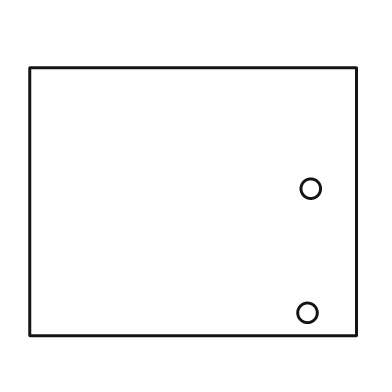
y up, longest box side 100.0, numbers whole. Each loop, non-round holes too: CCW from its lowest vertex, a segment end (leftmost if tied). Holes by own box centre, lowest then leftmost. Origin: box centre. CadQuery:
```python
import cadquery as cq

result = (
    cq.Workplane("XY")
    .moveTo(-50.0, -41.0)
    .lineTo(50.0, -41.0)
    .lineTo(50.0, 41.0)
    .lineTo(-50.0, 41.0)
    .close()
    .moveTo(35.0, -34.0)
    .circle(3.0)
    .moveTo(36.0, 4.0)
    .circle(3.0)
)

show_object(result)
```